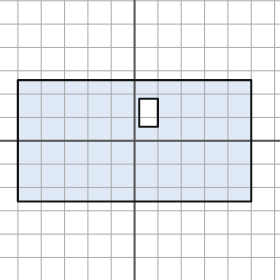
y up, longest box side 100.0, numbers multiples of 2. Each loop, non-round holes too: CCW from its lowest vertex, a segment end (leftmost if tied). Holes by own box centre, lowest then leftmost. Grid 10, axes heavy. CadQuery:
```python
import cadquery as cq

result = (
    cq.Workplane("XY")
    .moveTo(-50.0, -26.0)
    .lineTo(50.0, -26.0)
    .lineTo(50.0, 26.0)
    .lineTo(-50.0, 26.0)
    .close()
    .moveTo(2.0, 6.0)
    .lineTo(10.0, 6.0)
    .lineTo(10.0, 18.0)
    .lineTo(2.0, 18.0)
    .close()
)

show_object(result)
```